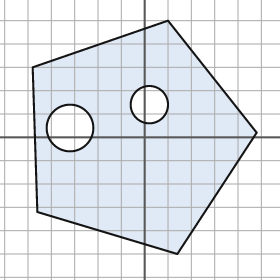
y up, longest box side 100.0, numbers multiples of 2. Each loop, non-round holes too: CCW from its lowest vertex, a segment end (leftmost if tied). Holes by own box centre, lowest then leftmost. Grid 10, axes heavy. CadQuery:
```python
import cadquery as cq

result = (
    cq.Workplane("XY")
    .moveTo(14.0, -50.0)
    .lineTo(48.0, 2.0)
    .lineTo(10.0, 50.0)
    .lineTo(-48.0, 30.0)
    .lineTo(-46.0, -32.0)
    .close()
    .moveTo(-32.0, 4.0)
    .circle(10.0)
    .moveTo(2.0, 14.0)
    .circle(8.0)
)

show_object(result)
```